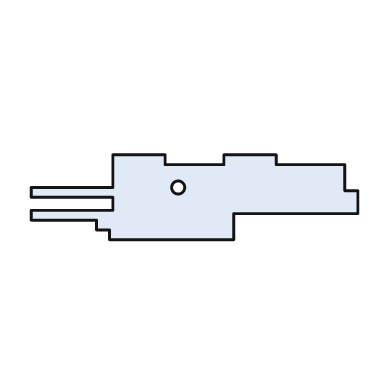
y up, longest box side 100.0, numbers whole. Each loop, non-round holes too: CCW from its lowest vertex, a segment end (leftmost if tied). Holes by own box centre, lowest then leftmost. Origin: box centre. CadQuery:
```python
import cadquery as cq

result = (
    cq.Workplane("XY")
    .moveTo(-26.0, -13.0)
    .lineTo(12.0, -13.0)
    .lineTo(12.0, -5.0)
    .lineTo(50.0, -5.0)
    .lineTo(50.0, 2.0)
    .lineTo(46.0, 2.0)
    .lineTo(46.0, 10.0)
    .lineTo(25.0, 10.0)
    .lineTo(25.0, 13.0)
    .lineTo(9.0, 13.0)
    .lineTo(9.0, 10.0)
    .lineTo(-9.0, 10.0)
    .lineTo(-9.0, 13.0)
    .lineTo(-25.0, 13.0)
    .lineTo(-25.0, 3.0)
    .lineTo(-50.0, 3.0)
    .lineTo(-50.0, 0.0)
    .lineTo(-25.0, 0.0)
    .lineTo(-25.0, -4.0)
    .lineTo(-50.0, -4.0)
    .lineTo(-50.0, -7.0)
    .lineTo(-30.0, -7.0)
    .lineTo(-30.0, -10.0)
    .lineTo(-26.0, -10.0)
    .close()
    .moveTo(-5.0, 3.0)
    .circle(2.0)
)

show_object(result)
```